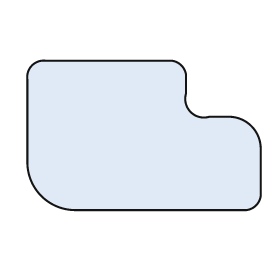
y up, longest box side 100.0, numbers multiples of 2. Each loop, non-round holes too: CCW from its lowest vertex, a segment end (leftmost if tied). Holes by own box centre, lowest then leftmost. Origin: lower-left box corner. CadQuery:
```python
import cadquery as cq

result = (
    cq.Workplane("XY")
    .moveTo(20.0, 0.0)
    .lineTo(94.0, 0.0)
    .threePointArc((98.0, 2.0), (100.0, 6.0))
    .lineTo(100.0, 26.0)
    .threePointArc((96.0, 36.0), (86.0, 40.0))
    .lineTo(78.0, 40.0)
    .threePointArc((70.0, 42.0), (68.0, 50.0))
    .lineTo(68.0, 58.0)
    .threePointArc((66.0, 62.0), (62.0, 64.0))
    .lineTo(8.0, 64.0)
    .threePointArc((2.0, 62.0), (0.0, 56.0))
    .lineTo(0.0, 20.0)
    .threePointArc((6.0, 6.0), (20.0, 0.0))
    .close()
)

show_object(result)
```